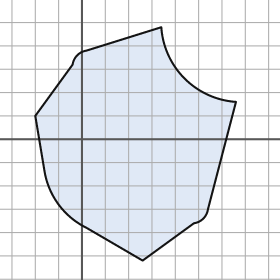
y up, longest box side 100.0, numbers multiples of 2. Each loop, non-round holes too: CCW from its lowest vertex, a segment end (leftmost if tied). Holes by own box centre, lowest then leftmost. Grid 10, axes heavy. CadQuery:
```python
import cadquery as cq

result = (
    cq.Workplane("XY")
    .moveTo(26.0, -52.0)
    .lineTo(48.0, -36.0)
    .threePointArc((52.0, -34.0), (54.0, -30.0))
    .lineTo(66.0, 16.0)
    .threePointArc((44.0, 26.0), (34.0, 48.0))
    .lineTo(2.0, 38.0)
    .threePointArc((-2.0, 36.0), (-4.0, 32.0))
    .lineTo(-20.0, 10.0)
    .lineTo(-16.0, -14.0)
    .threePointArc((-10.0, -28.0), (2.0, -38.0))
    .close()
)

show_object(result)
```